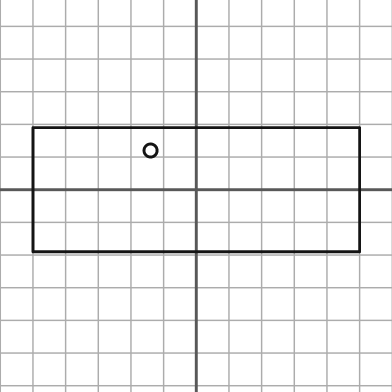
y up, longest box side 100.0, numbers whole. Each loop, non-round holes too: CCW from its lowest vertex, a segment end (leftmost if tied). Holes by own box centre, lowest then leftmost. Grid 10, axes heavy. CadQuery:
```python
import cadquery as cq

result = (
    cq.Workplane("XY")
    .moveTo(-50.0, -19.0)
    .lineTo(50.0, -19.0)
    .lineTo(50.0, 19.0)
    .lineTo(-50.0, 19.0)
    .close()
    .moveTo(-14.0, 12.0)
    .circle(2.0)
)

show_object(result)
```